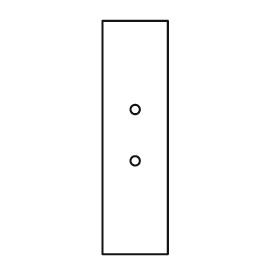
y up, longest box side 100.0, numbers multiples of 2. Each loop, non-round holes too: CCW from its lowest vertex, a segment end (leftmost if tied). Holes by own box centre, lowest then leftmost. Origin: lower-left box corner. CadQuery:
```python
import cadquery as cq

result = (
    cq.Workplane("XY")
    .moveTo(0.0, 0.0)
    .lineTo(28.0, 0.0)
    .lineTo(28.0, 100.0)
    .lineTo(0.0, 100.0)
    .close()
    .moveTo(14.0, 40.0)
    .circle(2.0)
    .moveTo(14.0, 62.0)
    .circle(2.0)
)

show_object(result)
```